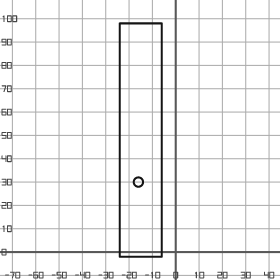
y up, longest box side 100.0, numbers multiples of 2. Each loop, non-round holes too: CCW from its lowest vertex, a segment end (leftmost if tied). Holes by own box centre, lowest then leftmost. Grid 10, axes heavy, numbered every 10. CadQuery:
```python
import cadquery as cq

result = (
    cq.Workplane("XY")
    .moveTo(-24.0, -2.0)
    .lineTo(-6.0, -2.0)
    .lineTo(-6.0, 98.0)
    .lineTo(-24.0, 98.0)
    .close()
    .moveTo(-16.0, 30.0)
    .circle(2.0)
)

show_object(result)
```